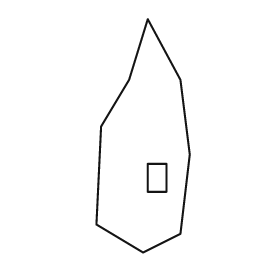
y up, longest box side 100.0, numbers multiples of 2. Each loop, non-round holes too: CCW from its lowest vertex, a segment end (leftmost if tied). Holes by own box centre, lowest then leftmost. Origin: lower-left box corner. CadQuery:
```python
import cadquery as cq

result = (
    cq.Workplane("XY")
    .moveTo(20.0, 0.0)
    .lineTo(36.0, 8.0)
    .lineTo(40.0, 42.0)
    .lineTo(36.0, 74.0)
    .lineTo(22.0, 100.0)
    .lineTo(14.0, 74.0)
    .lineTo(2.0, 54.0)
    .lineTo(0.0, 12.0)
    .close()
    .moveTo(22.0, 26.0)
    .lineTo(30.0, 26.0)
    .lineTo(30.0, 38.0)
    .lineTo(22.0, 38.0)
    .close()
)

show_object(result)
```